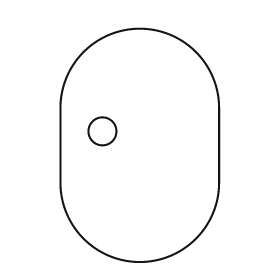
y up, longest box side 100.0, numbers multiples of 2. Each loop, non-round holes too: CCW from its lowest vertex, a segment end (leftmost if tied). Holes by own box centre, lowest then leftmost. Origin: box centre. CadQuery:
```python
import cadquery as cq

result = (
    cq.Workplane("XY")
    .moveTo(-34.0, -16.0)
    .threePointArc((0.0, -50.0), (34.0, -16.0))
    .lineTo(34.0, 16.0)
    .threePointArc((0.0, 50.0), (-34.0, 16.0))
    .close()
    .moveTo(-16.0, 6.0)
    .circle(6.0)
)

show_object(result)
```